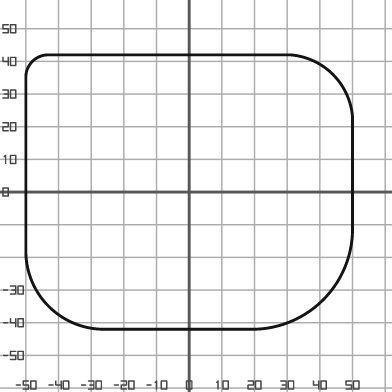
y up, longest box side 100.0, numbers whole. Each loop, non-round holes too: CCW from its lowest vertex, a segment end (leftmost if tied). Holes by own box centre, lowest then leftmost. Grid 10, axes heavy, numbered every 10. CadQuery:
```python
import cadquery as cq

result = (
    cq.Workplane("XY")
    .moveTo(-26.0, -42.0)
    .lineTo(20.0, -42.0)
    .threePointArc((41.0, -33.0), (50.0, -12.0))
    .lineTo(50.0, 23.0)
    .threePointArc((44.0, 36.0), (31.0, 42.0))
    .lineTo(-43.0, 42.0)
    .threePointArc((-48.0, 40.0), (-50.0, 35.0))
    .lineTo(-50.0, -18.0)
    .threePointArc((-43.0, -35.0), (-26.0, -42.0))
    .close()
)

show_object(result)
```